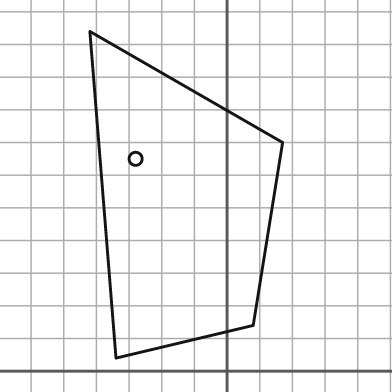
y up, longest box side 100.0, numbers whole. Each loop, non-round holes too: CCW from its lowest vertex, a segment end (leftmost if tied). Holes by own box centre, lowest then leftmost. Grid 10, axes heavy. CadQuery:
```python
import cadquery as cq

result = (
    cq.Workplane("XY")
    .moveTo(-34.0, 4.0)
    .lineTo(8.0, 14.0)
    .lineTo(17.0, 70.0)
    .lineTo(-42.0, 104.0)
    .close()
    .moveTo(-28.0, 65.0)
    .circle(2.0)
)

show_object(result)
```